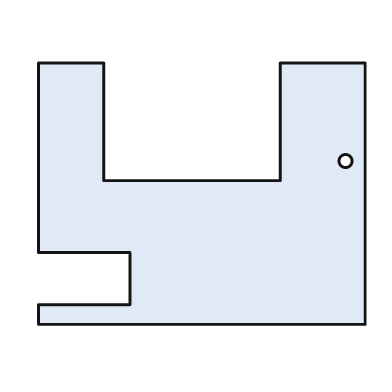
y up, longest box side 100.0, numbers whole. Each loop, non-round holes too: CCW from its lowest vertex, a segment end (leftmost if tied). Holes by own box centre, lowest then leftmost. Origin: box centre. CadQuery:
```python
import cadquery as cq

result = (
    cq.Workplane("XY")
    .moveTo(-50.0, -40.0)
    .lineTo(50.0, -40.0)
    .lineTo(50.0, 40.0)
    .lineTo(24.0, 40.0)
    .lineTo(24.0, 4.0)
    .lineTo(-30.0, 4.0)
    .lineTo(-30.0, 40.0)
    .lineTo(-50.0, 40.0)
    .lineTo(-50.0, -18.0)
    .lineTo(-22.0, -18.0)
    .lineTo(-22.0, -34.0)
    .lineTo(-50.0, -34.0)
    .close()
    .moveTo(44.0, 10.0)
    .circle(2.0)
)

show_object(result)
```